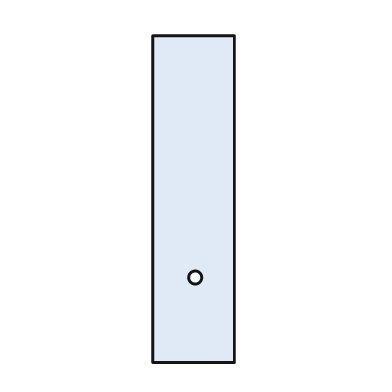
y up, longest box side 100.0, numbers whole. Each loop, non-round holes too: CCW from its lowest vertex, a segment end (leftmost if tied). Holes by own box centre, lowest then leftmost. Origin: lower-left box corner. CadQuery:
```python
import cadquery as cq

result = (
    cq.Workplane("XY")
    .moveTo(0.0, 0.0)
    .lineTo(25.0, 0.0)
    .lineTo(25.0, 100.0)
    .lineTo(0.0, 100.0)
    .close()
    .moveTo(13.0, 26.0)
    .circle(2.0)
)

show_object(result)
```